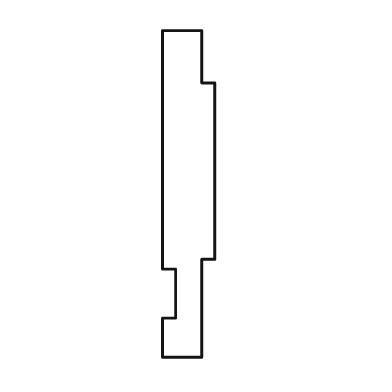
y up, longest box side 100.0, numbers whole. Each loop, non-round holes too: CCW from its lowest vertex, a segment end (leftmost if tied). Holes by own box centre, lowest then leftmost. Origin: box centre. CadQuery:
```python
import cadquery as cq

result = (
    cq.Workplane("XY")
    .moveTo(-8.0, -50.0)
    .lineTo(4.0, -50.0)
    .lineTo(4.0, -20.0)
    .lineTo(8.0, -20.0)
    .lineTo(8.0, 34.0)
    .lineTo(4.0, 34.0)
    .lineTo(4.0, 50.0)
    .lineTo(-8.0, 50.0)
    .lineTo(-8.0, -23.0)
    .lineTo(-4.0, -23.0)
    .lineTo(-4.0, -38.0)
    .lineTo(-8.0, -38.0)
    .close()
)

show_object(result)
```